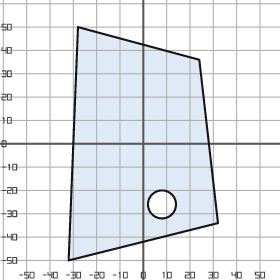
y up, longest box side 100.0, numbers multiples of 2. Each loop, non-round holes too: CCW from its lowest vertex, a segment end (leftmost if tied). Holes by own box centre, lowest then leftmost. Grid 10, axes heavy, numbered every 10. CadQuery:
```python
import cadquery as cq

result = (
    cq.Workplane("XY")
    .moveTo(-32.0, -50.0)
    .lineTo(32.0, -34.0)
    .lineTo(24.0, 36.0)
    .lineTo(-28.0, 50.0)
    .close()
    .moveTo(8.0, -26.0)
    .circle(6.0)
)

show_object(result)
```